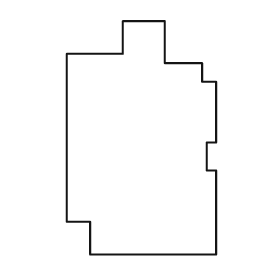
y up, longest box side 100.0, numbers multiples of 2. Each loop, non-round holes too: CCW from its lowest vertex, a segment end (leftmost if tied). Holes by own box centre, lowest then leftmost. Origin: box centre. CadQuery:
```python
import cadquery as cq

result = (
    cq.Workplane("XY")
    .moveTo(-22.0, -50.0)
    .lineTo(32.0, -50.0)
    .lineTo(32.0, -14.0)
    .lineTo(28.0, -14.0)
    .lineTo(28.0, -2.0)
    .lineTo(32.0, -2.0)
    .lineTo(32.0, 24.0)
    .lineTo(26.0, 24.0)
    .lineTo(26.0, 32.0)
    .lineTo(10.0, 32.0)
    .lineTo(10.0, 50.0)
    .lineTo(-8.0, 50.0)
    .lineTo(-8.0, 36.0)
    .lineTo(-32.0, 36.0)
    .lineTo(-32.0, -36.0)
    .lineTo(-22.0, -36.0)
    .close()
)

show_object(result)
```